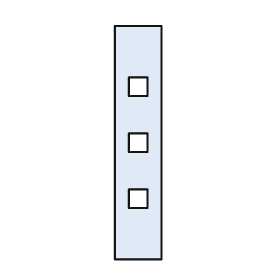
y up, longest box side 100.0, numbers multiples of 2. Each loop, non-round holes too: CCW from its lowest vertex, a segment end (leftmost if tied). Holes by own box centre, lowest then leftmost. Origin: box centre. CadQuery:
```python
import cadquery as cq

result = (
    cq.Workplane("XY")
    .moveTo(-10.0, -50.0)
    .lineTo(10.0, -50.0)
    .lineTo(10.0, 50.0)
    .lineTo(-10.0, 50.0)
    .close()
    .moveTo(-4.0, -28.0)
    .lineTo(4.0, -28.0)
    .lineTo(4.0, -20.0)
    .lineTo(-4.0, -20.0)
    .close()
    .moveTo(-4.0, -4.0)
    .lineTo(4.0, -4.0)
    .lineTo(4.0, 4.0)
    .lineTo(-4.0, 4.0)
    .close()
    .moveTo(-4.0, 20.0)
    .lineTo(4.0, 20.0)
    .lineTo(4.0, 28.0)
    .lineTo(-4.0, 28.0)
    .close()
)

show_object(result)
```